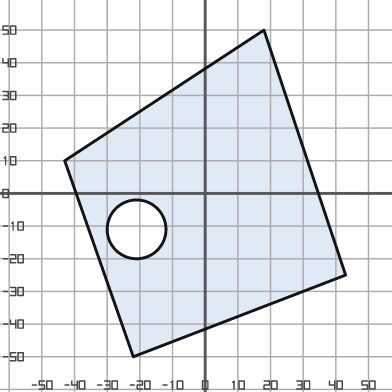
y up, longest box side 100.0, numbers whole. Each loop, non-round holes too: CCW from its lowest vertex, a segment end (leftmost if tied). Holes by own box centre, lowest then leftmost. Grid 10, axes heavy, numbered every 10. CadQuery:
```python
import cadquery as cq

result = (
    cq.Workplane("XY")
    .moveTo(-22.0, -50.0)
    .lineTo(43.0, -25.0)
    .lineTo(18.0, 50.0)
    .lineTo(-43.0, 10.0)
    .close()
    .moveTo(-21.0, -11.0)
    .circle(9.0)
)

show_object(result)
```